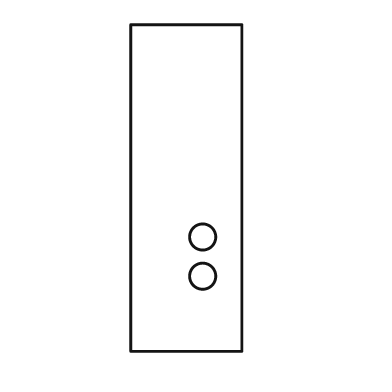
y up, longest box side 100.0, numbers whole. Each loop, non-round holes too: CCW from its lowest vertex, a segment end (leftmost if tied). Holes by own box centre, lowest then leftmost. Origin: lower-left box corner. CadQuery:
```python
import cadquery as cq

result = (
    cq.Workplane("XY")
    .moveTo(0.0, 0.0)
    .lineTo(34.0, 0.0)
    .lineTo(34.0, 100.0)
    .lineTo(0.0, 100.0)
    .close()
    .moveTo(22.0, 23.0)
    .circle(4.0)
    .moveTo(22.0, 35.0)
    .circle(4.0)
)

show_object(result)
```